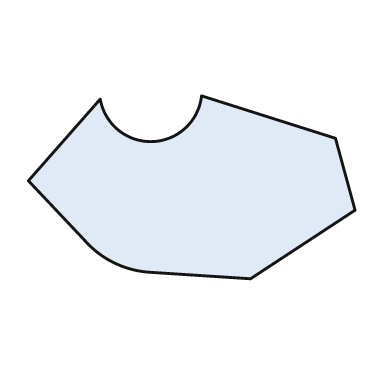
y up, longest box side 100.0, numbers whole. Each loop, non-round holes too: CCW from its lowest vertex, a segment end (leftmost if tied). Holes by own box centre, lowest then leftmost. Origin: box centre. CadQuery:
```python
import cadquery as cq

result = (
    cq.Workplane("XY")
    .moveTo(18.0, -28.0)
    .lineTo(50.0, -7.0)
    .lineTo(44.0, 15.0)
    .lineTo(3.0, 28.0)
    .threePointArc((-12.0, 14.0), (-28.0, 27.0))
    .lineTo(-50.0, 2.0)
    .lineTo(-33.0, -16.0)
    .threePointArc((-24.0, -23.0), (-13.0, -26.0))
    .close()
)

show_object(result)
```